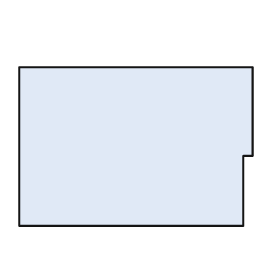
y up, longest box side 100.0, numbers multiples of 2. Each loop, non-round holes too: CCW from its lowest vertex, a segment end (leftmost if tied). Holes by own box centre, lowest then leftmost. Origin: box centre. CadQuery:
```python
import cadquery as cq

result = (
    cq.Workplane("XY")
    .moveTo(-50.0, -34.0)
    .lineTo(46.0, -34.0)
    .lineTo(46.0, -4.0)
    .lineTo(50.0, -4.0)
    .lineTo(50.0, 34.0)
    .lineTo(-50.0, 34.0)
    .close()
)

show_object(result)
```